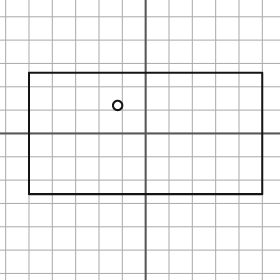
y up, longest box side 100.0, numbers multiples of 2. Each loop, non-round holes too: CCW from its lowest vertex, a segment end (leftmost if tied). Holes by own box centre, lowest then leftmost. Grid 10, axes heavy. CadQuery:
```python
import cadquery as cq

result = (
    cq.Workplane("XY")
    .moveTo(-50.0, -26.0)
    .lineTo(50.0, -26.0)
    .lineTo(50.0, 26.0)
    .lineTo(-50.0, 26.0)
    .close()
    .moveTo(-12.0, 12.0)
    .circle(2.0)
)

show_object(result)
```